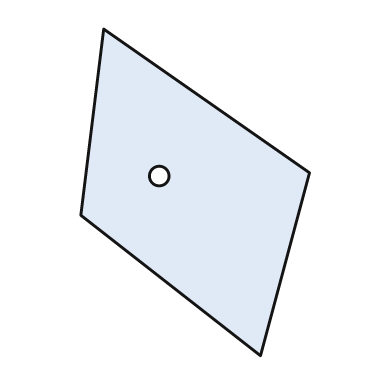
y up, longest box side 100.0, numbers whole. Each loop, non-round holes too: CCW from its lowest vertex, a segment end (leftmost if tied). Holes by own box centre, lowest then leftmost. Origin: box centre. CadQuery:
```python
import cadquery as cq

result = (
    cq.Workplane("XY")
    .moveTo(20.0, -50.0)
    .lineTo(35.0, 6.0)
    .lineTo(-28.0, 50.0)
    .lineTo(-35.0, -7.0)
    .close()
    .moveTo(-11.0, 5.0)
    .circle(3.0)
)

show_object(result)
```